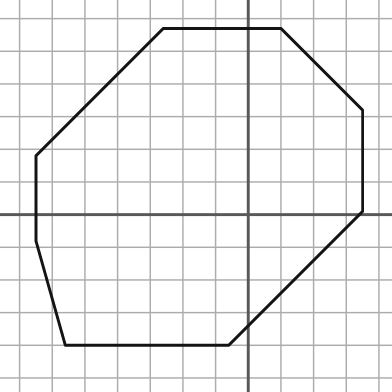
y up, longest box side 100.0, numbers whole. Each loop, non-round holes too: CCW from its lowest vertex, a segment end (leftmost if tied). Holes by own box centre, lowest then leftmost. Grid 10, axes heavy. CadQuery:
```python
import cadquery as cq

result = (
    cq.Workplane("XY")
    .moveTo(-56.0, -40.0)
    .lineTo(-6.0, -40.0)
    .lineTo(35.0, 1.0)
    .lineTo(35.0, 32.0)
    .lineTo(10.0, 57.0)
    .lineTo(-26.0, 57.0)
    .lineTo(-65.0, 18.0)
    .lineTo(-65.0, -8.0)
    .close()
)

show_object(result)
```